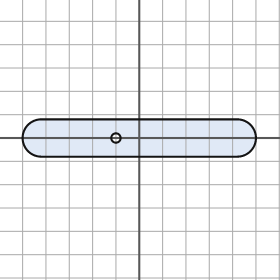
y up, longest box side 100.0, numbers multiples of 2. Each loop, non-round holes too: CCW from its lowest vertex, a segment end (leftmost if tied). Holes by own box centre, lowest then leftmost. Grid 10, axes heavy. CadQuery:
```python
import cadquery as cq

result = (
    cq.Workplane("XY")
    .moveTo(-42.0, -8.0)
    .lineTo(42.0, -8.0)
    .threePointArc((50.0, 0.0), (42.0, 8.0))
    .lineTo(-42.0, 8.0)
    .threePointArc((-50.0, 0.0), (-42.0, -8.0))
    .close()
    .moveTo(-10.0, 0.0)
    .circle(2.0)
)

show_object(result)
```